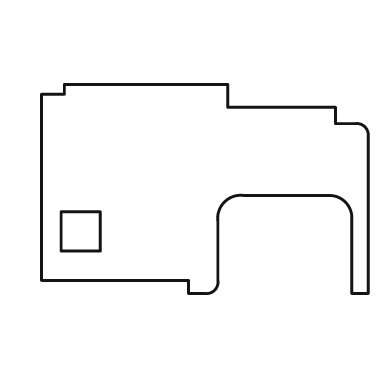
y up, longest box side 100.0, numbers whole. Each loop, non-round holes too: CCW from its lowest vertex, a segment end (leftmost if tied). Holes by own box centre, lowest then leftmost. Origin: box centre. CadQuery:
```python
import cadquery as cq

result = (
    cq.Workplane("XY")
    .moveTo(-5.0, -32.0)
    .lineTo(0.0, -32.0)
    .threePointArc((3.0, -31.0), (4.0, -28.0))
    .lineTo(4.0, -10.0)
    .threePointArc((6.0, -4.0), (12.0, -2.0))
    .lineTo(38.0, -2.0)
    .threePointArc((43.0, -4.0), (45.0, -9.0))
    .lineTo(45.0, -32.0)
    .lineTo(50.0, -32.0)
    .lineTo(50.0, 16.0)
    .threePointArc((49.0, 19.0), (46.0, 20.0))
    .lineTo(40.0, 20.0)
    .lineTo(40.0, 25.0)
    .lineTo(7.0, 25.0)
    .lineTo(7.0, 32.0)
    .lineTo(-43.0, 32.0)
    .lineTo(-43.0, 29.0)
    .lineTo(-50.0, 29.0)
    .lineTo(-50.0, -28.0)
    .lineTo(-5.0, -28.0)
    .close()
    .moveTo(-44.0, -19.0)
    .lineTo(-32.0, -19.0)
    .lineTo(-32.0, -7.0)
    .lineTo(-44.0, -7.0)
    .close()
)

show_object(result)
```